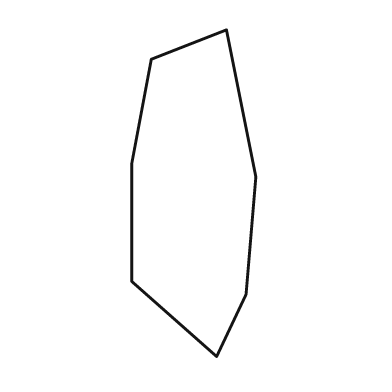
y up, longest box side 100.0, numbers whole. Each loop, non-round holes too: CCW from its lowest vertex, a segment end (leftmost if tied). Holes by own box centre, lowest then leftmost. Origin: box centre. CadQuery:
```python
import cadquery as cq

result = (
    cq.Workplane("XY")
    .moveTo(7.0, -50.0)
    .lineTo(16.0, -31.0)
    .lineTo(19.0, 5.0)
    .lineTo(10.0, 50.0)
    .lineTo(-13.0, 41.0)
    .lineTo(-19.0, 9.0)
    .lineTo(-19.0, -27.0)
    .close()
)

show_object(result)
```